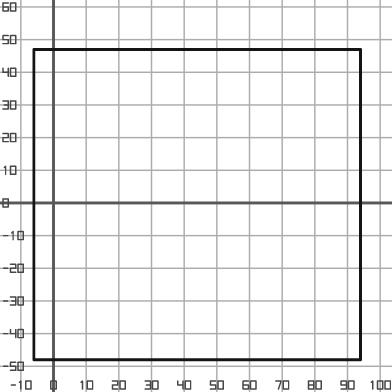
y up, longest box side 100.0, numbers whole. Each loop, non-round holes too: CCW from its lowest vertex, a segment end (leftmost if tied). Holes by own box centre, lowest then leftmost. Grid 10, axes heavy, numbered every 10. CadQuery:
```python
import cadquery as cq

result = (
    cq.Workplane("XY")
    .moveTo(-6.0, -48.0)
    .lineTo(94.0, -48.0)
    .lineTo(94.0, 47.0)
    .lineTo(-6.0, 47.0)
    .close()
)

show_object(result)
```